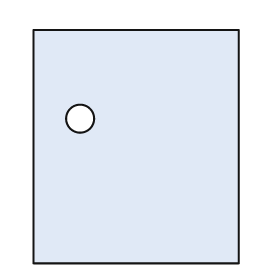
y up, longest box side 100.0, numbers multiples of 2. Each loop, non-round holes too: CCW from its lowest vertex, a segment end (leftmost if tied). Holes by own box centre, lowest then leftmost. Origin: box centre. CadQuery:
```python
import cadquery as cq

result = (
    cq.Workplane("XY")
    .moveTo(-44.0, -50.0)
    .lineTo(44.0, -50.0)
    .lineTo(44.0, 50.0)
    .lineTo(-44.0, 50.0)
    .close()
    .moveTo(-24.0, 12.0)
    .circle(6.0)
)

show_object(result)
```